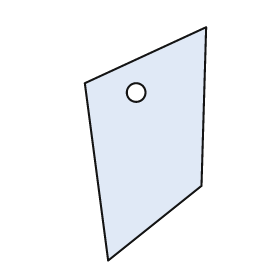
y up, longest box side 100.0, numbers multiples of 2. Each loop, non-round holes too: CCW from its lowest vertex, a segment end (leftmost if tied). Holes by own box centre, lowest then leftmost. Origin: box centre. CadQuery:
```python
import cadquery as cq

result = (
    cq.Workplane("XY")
    .moveTo(-16.0, -50.0)
    .lineTo(24.0, -18.0)
    .lineTo(26.0, 50.0)
    .lineTo(-26.0, 26.0)
    .close()
    .moveTo(-4.0, 22.0)
    .circle(4.0)
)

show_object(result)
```